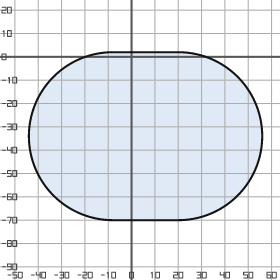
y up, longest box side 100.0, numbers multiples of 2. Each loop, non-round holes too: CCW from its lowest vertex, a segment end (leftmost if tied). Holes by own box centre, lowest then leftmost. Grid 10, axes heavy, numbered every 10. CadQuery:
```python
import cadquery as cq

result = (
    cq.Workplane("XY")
    .moveTo(-8.0, -70.0)
    .lineTo(20.0, -70.0)
    .threePointArc((56.0, -34.0), (20.0, 2.0))
    .lineTo(-8.0, 2.0)
    .threePointArc((-44.0, -34.0), (-8.0, -70.0))
    .close()
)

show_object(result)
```